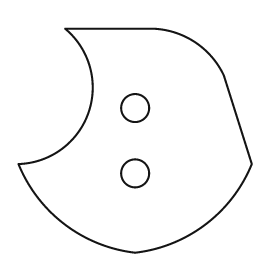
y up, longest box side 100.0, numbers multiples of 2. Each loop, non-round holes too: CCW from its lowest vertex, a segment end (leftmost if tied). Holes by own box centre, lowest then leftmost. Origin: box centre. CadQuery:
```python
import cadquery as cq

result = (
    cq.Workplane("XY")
    .moveTo(0.0, -48.0)
    .threePointArc((30.0, -36.0), (50.0, -10.0))
    .lineTo(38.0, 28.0)
    .threePointArc((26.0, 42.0), (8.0, 48.0))
    .lineTo(-30.0, 48.0)
    .threePointArc((-20.0, 12.0), (-50.0, -10.0))
    .threePointArc((-30.0, -36.0), (0.0, -48.0))
    .close()
    .moveTo(0.0, -14.0)
    .circle(6.0)
    .moveTo(0.0, 14.0)
    .circle(6.0)
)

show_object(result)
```